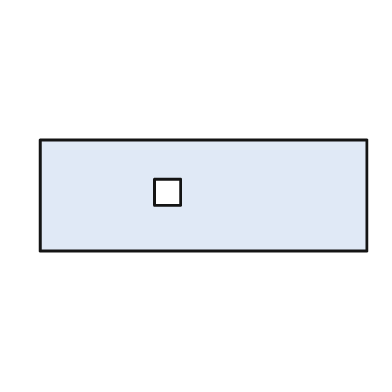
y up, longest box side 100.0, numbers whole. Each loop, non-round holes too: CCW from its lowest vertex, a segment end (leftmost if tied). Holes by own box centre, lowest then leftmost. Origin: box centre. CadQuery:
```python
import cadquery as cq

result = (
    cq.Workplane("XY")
    .moveTo(-50.0, -17.0)
    .lineTo(50.0, -17.0)
    .lineTo(50.0, 17.0)
    .lineTo(-50.0, 17.0)
    .close()
    .moveTo(-15.0, -3.0)
    .lineTo(-7.0, -3.0)
    .lineTo(-7.0, 5.0)
    .lineTo(-15.0, 5.0)
    .close()
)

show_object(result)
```